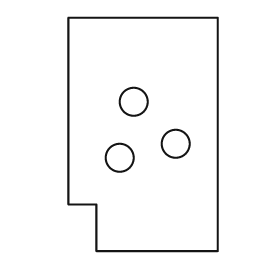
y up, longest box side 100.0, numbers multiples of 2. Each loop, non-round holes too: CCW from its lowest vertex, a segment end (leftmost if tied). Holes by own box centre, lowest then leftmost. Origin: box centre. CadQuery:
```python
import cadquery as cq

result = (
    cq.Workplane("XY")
    .moveTo(-20.0, -50.0)
    .lineTo(32.0, -50.0)
    .lineTo(32.0, 50.0)
    .lineTo(-32.0, 50.0)
    .lineTo(-32.0, -30.0)
    .lineTo(-20.0, -30.0)
    .close()
    .moveTo(-10.0, -10.0)
    .circle(6.0)
    .moveTo(14.0, -4.0)
    .circle(6.0)
    .moveTo(-4.0, 14.0)
    .circle(6.0)
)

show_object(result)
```